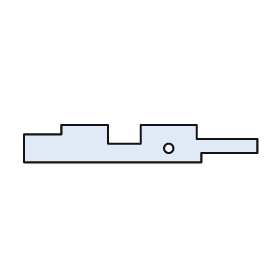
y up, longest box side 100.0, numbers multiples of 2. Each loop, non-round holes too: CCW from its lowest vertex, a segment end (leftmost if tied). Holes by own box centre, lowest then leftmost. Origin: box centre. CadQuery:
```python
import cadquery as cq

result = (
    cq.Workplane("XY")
    .moveTo(-50.0, -8.0)
    .lineTo(26.0, -8.0)
    .lineTo(26.0, -4.0)
    .lineTo(50.0, -4.0)
    .lineTo(50.0, 2.0)
    .lineTo(24.0, 2.0)
    .lineTo(24.0, 8.0)
    .lineTo(0.0, 8.0)
    .lineTo(0.0, 0.0)
    .lineTo(-14.0, 0.0)
    .lineTo(-14.0, 8.0)
    .lineTo(-34.0, 8.0)
    .lineTo(-34.0, 4.0)
    .lineTo(-50.0, 4.0)
    .close()
    .moveTo(12.0, -2.0)
    .circle(2.0)
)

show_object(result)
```